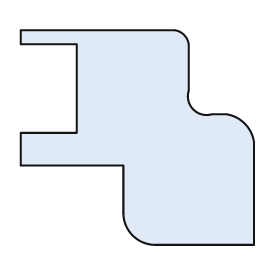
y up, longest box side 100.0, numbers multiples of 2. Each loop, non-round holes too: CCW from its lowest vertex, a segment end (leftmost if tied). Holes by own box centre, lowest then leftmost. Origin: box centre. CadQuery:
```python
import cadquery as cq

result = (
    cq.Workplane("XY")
    .moveTo(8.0, -46.0)
    .lineTo(50.0, -46.0)
    .lineTo(50.0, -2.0)
    .threePointArc((46.0, 6.0), (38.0, 10.0))
    .lineTo(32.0, 10.0)
    .threePointArc((24.0, 12.0), (22.0, 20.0))
    .lineTo(22.0, 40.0)
    .threePointArc((20.0, 44.0), (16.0, 46.0))
    .lineTo(-50.0, 46.0)
    .lineTo(-50.0, 40.0)
    .lineTo(-26.0, 40.0)
    .lineTo(-26.0, 2.0)
    .lineTo(-50.0, 2.0)
    .lineTo(-50.0, -12.0)
    .lineTo(-6.0, -12.0)
    .lineTo(-6.0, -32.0)
    .threePointArc((-2.0, -42.0), (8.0, -46.0))
    .close()
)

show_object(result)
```